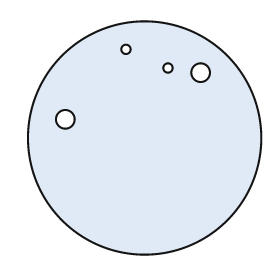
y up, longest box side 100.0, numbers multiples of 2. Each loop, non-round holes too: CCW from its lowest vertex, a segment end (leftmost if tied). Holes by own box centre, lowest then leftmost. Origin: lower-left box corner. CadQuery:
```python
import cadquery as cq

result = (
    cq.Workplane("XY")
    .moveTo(50.0, 50.0)
    .circle(50.0)
    .moveTo(16.0, 58.0)
    .circle(4.0)
    .moveTo(74.0, 78.0)
    .circle(4.0)
    .moveTo(60.0, 80.0)
    .circle(2.0)
    .moveTo(42.0, 88.0)
    .circle(2.0)
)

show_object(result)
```